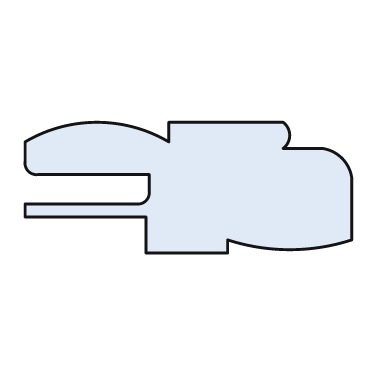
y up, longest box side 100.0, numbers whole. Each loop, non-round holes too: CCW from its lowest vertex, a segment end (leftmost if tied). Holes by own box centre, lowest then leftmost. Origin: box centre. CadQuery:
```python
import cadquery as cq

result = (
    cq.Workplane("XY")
    .moveTo(-13.0, -20.0)
    .lineTo(12.0, -20.0)
    .lineTo(12.0, -16.0)
    .threePointArc((31.0, -19.0), (50.0, -16.0))
    .lineTo(50.0, 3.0)
    .threePointArc((47.0, 9.0), (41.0, 12.0))
    .lineTo(29.0, 12.0)
    .threePointArc((31.0, 16.0), (29.0, 20.0))
    .lineTo(-6.0, 20.0)
    .lineTo(-6.0, 14.0)
    .threePointArc((-28.0, 20.0), (-50.0, 14.0))
    .lineTo(-50.0, 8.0)
    .threePointArc((-49.0, 5.0), (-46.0, 4.0))
    .lineTo(-12.0, 4.0)
    .lineTo(-12.0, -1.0)
    .threePointArc((-13.0, -4.0), (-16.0, -5.0))
    .lineTo(-50.0, -5.0)
    .lineTo(-50.0, -9.0)
    .lineTo(-13.0, -9.0)
    .close()
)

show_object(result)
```